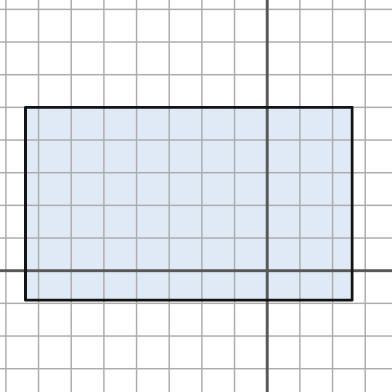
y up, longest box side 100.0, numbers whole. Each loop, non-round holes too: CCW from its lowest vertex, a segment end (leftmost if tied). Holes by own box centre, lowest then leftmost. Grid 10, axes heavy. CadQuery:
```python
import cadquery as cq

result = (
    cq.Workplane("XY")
    .moveTo(-74.0, -9.0)
    .lineTo(26.0, -9.0)
    .lineTo(26.0, 50.0)
    .lineTo(-74.0, 50.0)
    .close()
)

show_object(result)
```